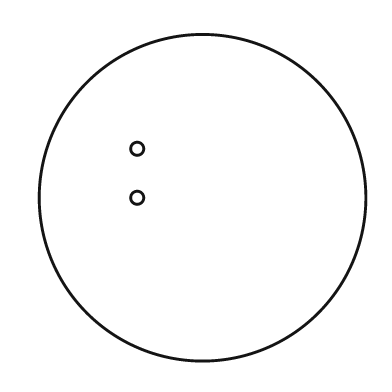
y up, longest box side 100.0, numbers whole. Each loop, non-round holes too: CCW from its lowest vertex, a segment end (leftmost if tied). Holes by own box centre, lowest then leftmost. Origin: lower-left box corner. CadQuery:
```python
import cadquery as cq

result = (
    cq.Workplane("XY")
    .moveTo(50.0, 50.0)
    .circle(50.0)
    .moveTo(30.0, 50.0)
    .circle(2.0)
    .moveTo(30.0, 65.0)
    .circle(2.0)
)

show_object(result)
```